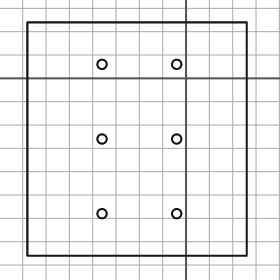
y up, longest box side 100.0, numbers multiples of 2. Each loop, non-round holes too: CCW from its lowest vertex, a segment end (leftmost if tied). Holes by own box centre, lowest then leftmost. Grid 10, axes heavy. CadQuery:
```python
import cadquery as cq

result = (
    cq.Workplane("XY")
    .moveTo(-68.0, -76.0)
    .lineTo(26.0, -76.0)
    .lineTo(26.0, 24.0)
    .lineTo(-68.0, 24.0)
    .close()
    .moveTo(-36.0, -58.0)
    .circle(2.0)
    .moveTo(-4.0, -58.0)
    .circle(2.0)
    .moveTo(-36.0, -26.0)
    .circle(2.0)
    .moveTo(-4.0, -26.0)
    .circle(2.0)
    .moveTo(-36.0, 6.0)
    .circle(2.0)
    .moveTo(-4.0, 6.0)
    .circle(2.0)
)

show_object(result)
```